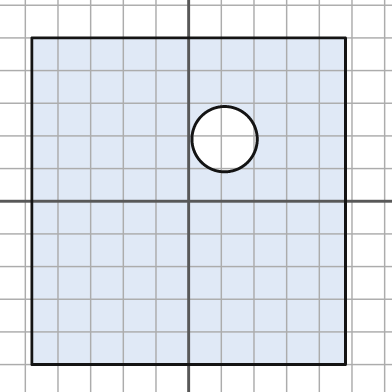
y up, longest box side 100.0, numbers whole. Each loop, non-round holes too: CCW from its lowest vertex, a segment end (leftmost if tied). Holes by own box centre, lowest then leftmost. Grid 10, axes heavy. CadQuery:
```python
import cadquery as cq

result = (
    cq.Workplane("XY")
    .moveTo(-48.0, -50.0)
    .lineTo(48.0, -50.0)
    .lineTo(48.0, 50.0)
    .lineTo(-48.0, 50.0)
    .close()
    .moveTo(11.0, 19.0)
    .circle(10.0)
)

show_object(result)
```